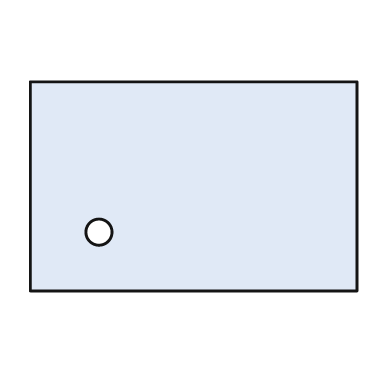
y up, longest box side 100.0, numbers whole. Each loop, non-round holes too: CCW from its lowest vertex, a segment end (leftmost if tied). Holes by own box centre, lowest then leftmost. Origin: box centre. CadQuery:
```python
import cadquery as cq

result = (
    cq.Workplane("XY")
    .moveTo(-50.0, -32.0)
    .lineTo(50.0, -32.0)
    .lineTo(50.0, 32.0)
    .lineTo(-50.0, 32.0)
    .close()
    .moveTo(-29.0, -14.0)
    .circle(4.0)
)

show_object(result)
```